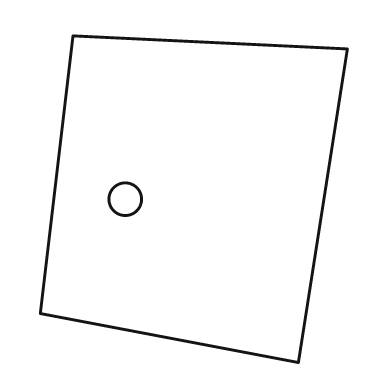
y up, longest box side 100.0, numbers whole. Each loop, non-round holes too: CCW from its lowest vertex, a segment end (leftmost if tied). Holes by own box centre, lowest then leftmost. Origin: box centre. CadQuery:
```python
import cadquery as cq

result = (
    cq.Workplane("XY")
    .moveTo(32.0, -50.0)
    .lineTo(47.0, 46.0)
    .lineTo(-37.0, 50.0)
    .lineTo(-47.0, -35.0)
    .close()
    .moveTo(-21.0, 0.0)
    .circle(5.0)
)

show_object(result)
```